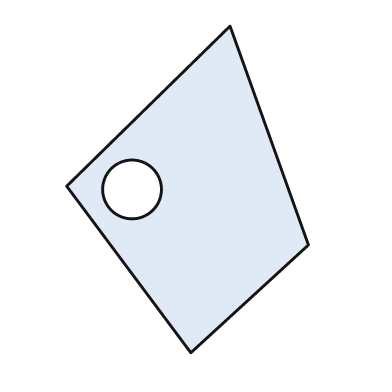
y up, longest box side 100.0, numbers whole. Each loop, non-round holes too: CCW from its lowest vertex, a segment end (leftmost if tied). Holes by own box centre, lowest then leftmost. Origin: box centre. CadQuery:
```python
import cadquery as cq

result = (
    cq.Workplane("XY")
    .moveTo(1.0, -50.0)
    .lineTo(37.0, -17.0)
    .lineTo(13.0, 50.0)
    .lineTo(-37.0, 1.0)
    .close()
    .moveTo(-17.0, 0.0)
    .circle(9.0)
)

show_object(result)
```